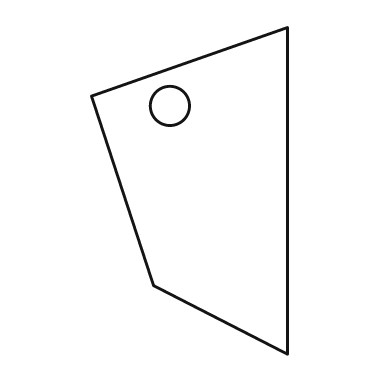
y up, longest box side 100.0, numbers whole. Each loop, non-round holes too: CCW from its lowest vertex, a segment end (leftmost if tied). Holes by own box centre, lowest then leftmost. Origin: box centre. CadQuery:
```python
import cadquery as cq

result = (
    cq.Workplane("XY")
    .moveTo(30.0, -50.0)
    .lineTo(30.0, 50.0)
    .lineTo(-30.0, 29.0)
    .lineTo(-11.0, -29.0)
    .close()
    .moveTo(-6.0, 26.0)
    .circle(6.0)
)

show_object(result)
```